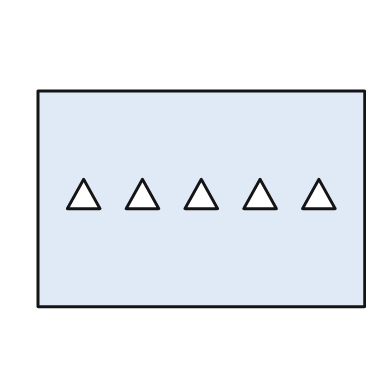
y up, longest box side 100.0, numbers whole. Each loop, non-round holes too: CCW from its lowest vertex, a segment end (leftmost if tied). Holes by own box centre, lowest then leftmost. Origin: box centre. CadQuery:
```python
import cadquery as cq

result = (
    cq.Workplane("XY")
    .moveTo(-50.0, -33.0)
    .lineTo(50.0, -33.0)
    .lineTo(50.0, 33.0)
    .lineTo(-50.0, 33.0)
    .close()
    .moveTo(-41.0, -3.0)
    .lineTo(-31.0, -3.0)
    .lineTo(-36.0, 6.0)
    .close()
    .moveTo(-23.0, -3.0)
    .lineTo(-13.0, -3.0)
    .lineTo(-18.0, 6.0)
    .close()
    .moveTo(-5.0, -3.0)
    .lineTo(5.0, -3.0)
    .lineTo(0.0, 6.0)
    .close()
    .moveTo(13.0, -3.0)
    .lineTo(23.0, -3.0)
    .lineTo(18.0, 6.0)
    .close()
    .moveTo(31.0, -3.0)
    .lineTo(41.0, -3.0)
    .lineTo(36.0, 6.0)
    .close()
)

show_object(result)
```